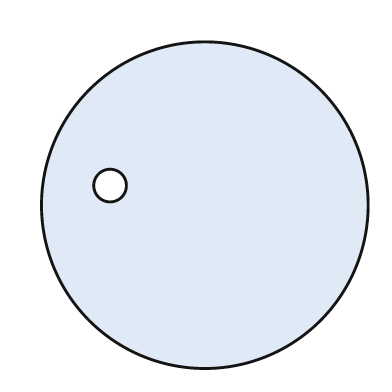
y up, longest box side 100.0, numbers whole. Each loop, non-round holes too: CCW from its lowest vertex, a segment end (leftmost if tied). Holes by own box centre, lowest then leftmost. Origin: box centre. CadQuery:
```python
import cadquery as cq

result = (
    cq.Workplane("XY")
    .moveTo(0.0, 0.0)
    .circle(50.0)
    .moveTo(-29.0, 6.0)
    .circle(5.0)
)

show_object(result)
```